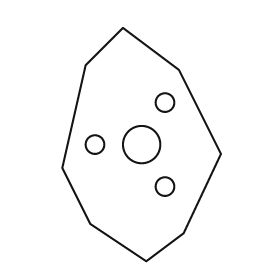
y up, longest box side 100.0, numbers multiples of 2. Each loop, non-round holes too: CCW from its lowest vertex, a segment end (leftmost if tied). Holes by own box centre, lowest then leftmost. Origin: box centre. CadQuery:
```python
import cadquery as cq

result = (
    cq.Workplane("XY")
    .moveTo(2.0, -50.0)
    .lineTo(18.0, -38.0)
    .lineTo(34.0, -4.0)
    .lineTo(16.0, 32.0)
    .lineTo(-8.0, 50.0)
    .lineTo(-24.0, 34.0)
    .lineTo(-34.0, -10.0)
    .lineTo(-22.0, -34.0)
    .close()
    .moveTo(10.0, -18.0)
    .circle(4.0)
    .moveTo(-20.0, 0.0)
    .circle(4.0)
    .moveTo(0.0, 0.0)
    .circle(8.0)
    .moveTo(10.0, 18.0)
    .circle(4.0)
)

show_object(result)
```